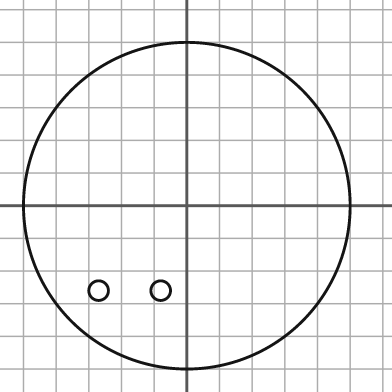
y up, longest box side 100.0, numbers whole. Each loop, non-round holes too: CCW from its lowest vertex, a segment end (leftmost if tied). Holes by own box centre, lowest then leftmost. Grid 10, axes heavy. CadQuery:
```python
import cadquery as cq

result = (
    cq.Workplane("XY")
    .moveTo(0.0, 0.0)
    .circle(50.0)
    .moveTo(-27.0, -26.0)
    .circle(3.0)
    .moveTo(-8.0, -26.0)
    .circle(3.0)
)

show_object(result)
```